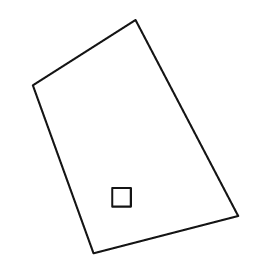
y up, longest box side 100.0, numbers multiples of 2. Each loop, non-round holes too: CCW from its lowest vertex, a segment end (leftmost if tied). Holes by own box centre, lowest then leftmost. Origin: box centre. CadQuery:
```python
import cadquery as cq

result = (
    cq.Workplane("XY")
    .moveTo(-18.0, -50.0)
    .lineTo(44.0, -34.0)
    .lineTo(0.0, 50.0)
    .lineTo(-44.0, 22.0)
    .close()
    .moveTo(-10.0, -30.0)
    .lineTo(-2.0, -30.0)
    .lineTo(-2.0, -22.0)
    .lineTo(-10.0, -22.0)
    .close()
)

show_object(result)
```